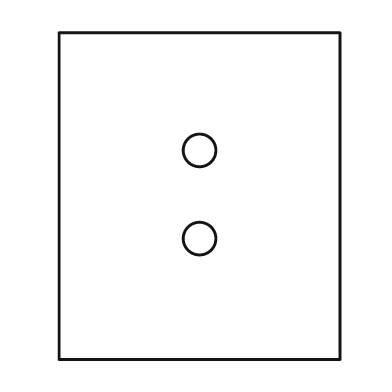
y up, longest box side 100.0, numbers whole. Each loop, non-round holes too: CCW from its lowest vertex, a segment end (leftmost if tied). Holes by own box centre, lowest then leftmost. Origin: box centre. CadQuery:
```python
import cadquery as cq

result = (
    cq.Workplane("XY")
    .moveTo(-43.0, -50.0)
    .lineTo(43.0, -50.0)
    .lineTo(43.0, 50.0)
    .lineTo(-43.0, 50.0)
    .close()
    .moveTo(0.0, -13.0)
    .circle(5.0)
    .moveTo(0.0, 14.0)
    .circle(5.0)
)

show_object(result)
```